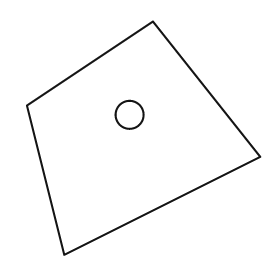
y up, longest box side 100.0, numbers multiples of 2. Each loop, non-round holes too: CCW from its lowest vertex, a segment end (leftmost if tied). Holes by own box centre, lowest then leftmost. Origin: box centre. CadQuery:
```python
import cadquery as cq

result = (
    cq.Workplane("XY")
    .moveTo(-34.0, -50.0)
    .lineTo(50.0, -8.0)
    .lineTo(4.0, 50.0)
    .lineTo(-50.0, 14.0)
    .close()
    .moveTo(-6.0, 10.0)
    .circle(6.0)
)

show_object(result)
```